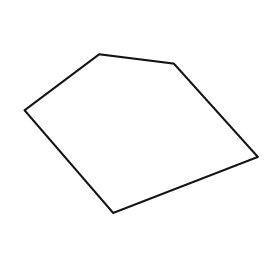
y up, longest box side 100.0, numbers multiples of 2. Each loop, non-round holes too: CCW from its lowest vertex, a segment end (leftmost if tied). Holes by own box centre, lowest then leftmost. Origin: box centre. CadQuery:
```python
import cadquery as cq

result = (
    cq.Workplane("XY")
    .moveTo(-12.0, -34.0)
    .lineTo(50.0, -10.0)
    .lineTo(14.0, 30.0)
    .lineTo(-18.0, 34.0)
    .lineTo(-50.0, 10.0)
    .close()
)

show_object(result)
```